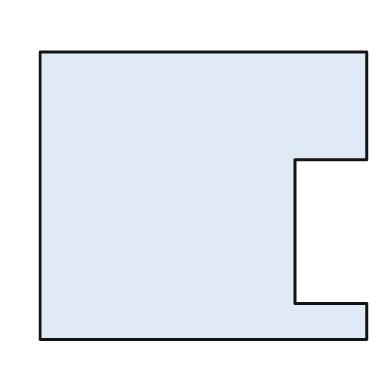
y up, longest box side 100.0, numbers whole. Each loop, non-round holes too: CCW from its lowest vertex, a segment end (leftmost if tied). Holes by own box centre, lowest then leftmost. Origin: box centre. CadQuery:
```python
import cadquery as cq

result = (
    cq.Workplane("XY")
    .moveTo(-50.0, -44.0)
    .lineTo(50.0, -44.0)
    .lineTo(50.0, -33.0)
    .lineTo(28.0, -33.0)
    .lineTo(28.0, 11.0)
    .lineTo(50.0, 11.0)
    .lineTo(50.0, 44.0)
    .lineTo(-50.0, 44.0)
    .close()
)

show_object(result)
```